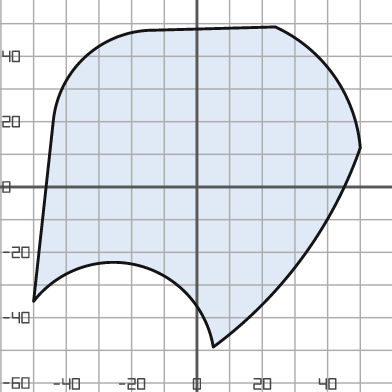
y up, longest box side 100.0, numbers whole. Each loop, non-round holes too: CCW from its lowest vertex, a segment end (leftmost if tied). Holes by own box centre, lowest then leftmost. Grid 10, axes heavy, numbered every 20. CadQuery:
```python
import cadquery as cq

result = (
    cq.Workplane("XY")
    .moveTo(5.0, -49.0)
    .threePointArc((32.0, -22.0), (50.0, 12.0))
    .threePointArc((42.0, 34.0), (24.0, 49.0))
    .lineTo(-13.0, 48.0)
    .threePointArc((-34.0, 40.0), (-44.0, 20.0))
    .lineTo(-50.0, -35.0)
    .threePointArc((-18.0, -24.0), (5.0, -49.0))
    .close()
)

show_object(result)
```